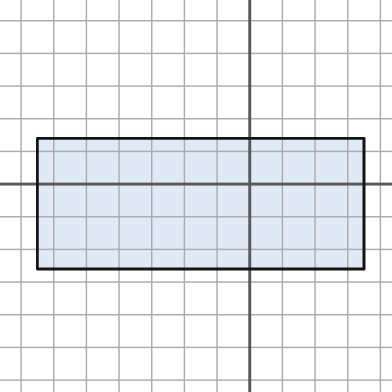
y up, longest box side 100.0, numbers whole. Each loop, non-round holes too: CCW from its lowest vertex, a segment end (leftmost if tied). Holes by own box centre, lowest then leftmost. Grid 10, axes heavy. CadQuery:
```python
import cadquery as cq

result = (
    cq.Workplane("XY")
    .moveTo(-65.0, -26.0)
    .lineTo(35.0, -26.0)
    .lineTo(35.0, 14.0)
    .lineTo(-65.0, 14.0)
    .close()
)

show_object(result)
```